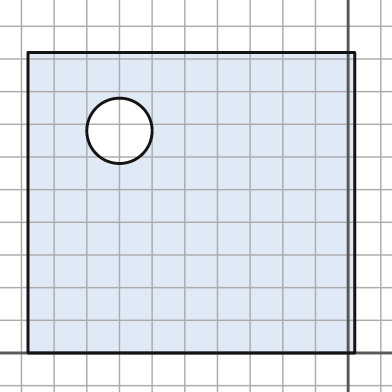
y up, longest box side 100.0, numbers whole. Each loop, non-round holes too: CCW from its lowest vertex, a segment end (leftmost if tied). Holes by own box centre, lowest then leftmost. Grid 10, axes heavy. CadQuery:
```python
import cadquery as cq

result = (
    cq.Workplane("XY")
    .moveTo(-98.0, 0.0)
    .lineTo(2.0, 0.0)
    .lineTo(2.0, 92.0)
    .lineTo(-98.0, 92.0)
    .close()
    .moveTo(-70.0, 68.0)
    .circle(10.0)
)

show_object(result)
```